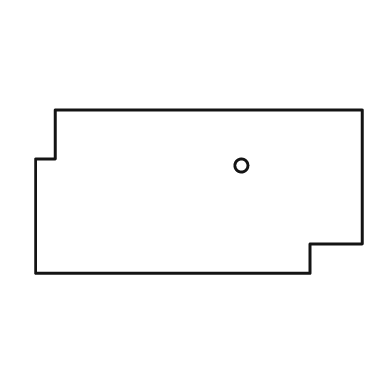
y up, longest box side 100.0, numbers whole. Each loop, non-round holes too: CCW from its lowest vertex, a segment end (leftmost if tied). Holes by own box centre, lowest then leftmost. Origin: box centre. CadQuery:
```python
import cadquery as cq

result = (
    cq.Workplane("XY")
    .moveTo(-50.0, -25.0)
    .lineTo(34.0, -25.0)
    .lineTo(34.0, -16.0)
    .lineTo(50.0, -16.0)
    .lineTo(50.0, 25.0)
    .lineTo(-44.0, 25.0)
    .lineTo(-44.0, 10.0)
    .lineTo(-50.0, 10.0)
    .close()
    .moveTo(13.0, 8.0)
    .circle(2.0)
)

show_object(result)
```